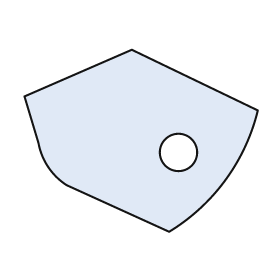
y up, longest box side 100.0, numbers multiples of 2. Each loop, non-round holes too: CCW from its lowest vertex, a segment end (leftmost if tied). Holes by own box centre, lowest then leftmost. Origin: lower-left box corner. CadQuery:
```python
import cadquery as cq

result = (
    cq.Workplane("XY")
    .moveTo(62.0, 0.0)
    .threePointArc((86.0, 22.0), (100.0, 52.0))
    .lineTo(46.0, 78.0)
    .lineTo(0.0, 58.0)
    .lineTo(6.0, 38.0)
    .threePointArc((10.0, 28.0), (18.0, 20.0))
    .close()
    .moveTo(66.0, 34.0)
    .circle(8.0)
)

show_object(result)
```